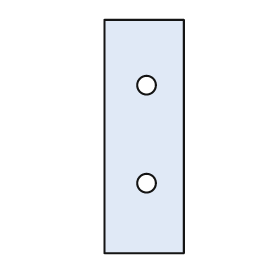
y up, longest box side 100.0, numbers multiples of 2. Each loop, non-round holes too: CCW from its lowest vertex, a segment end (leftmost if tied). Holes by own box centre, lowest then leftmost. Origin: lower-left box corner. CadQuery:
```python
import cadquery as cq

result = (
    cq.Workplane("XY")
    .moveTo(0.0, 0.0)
    .lineTo(34.0, 0.0)
    .lineTo(34.0, 100.0)
    .lineTo(0.0, 100.0)
    .close()
    .moveTo(18.0, 30.0)
    .circle(4.0)
    .moveTo(18.0, 72.0)
    .circle(4.0)
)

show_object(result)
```